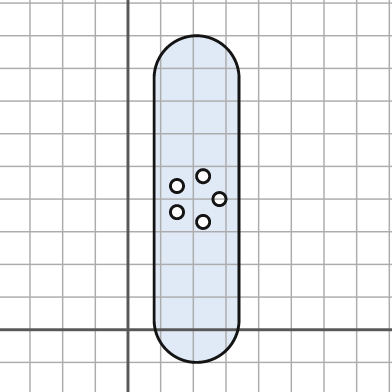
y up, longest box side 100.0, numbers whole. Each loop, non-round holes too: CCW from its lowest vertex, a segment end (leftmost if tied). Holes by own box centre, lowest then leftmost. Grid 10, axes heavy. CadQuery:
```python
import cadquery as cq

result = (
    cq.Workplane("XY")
    .moveTo(8.0, 3.0)
    .threePointArc((21.0, -10.0), (34.0, 3.0))
    .lineTo(34.0, 77.0)
    .threePointArc((21.0, 90.0), (8.0, 77.0))
    .close()
    .moveTo(23.0, 33.0)
    .circle(2.0)
    .moveTo(15.0, 36.0)
    .circle(2.0)
    .moveTo(28.0, 40.0)
    .circle(2.0)
    .moveTo(15.0, 44.0)
    .circle(2.0)
    .moveTo(23.0, 47.0)
    .circle(2.0)
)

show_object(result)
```